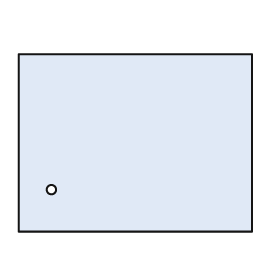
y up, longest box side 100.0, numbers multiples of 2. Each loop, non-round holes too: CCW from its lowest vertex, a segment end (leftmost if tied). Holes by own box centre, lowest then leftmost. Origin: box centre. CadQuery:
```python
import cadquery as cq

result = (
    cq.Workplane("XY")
    .moveTo(-50.0, -38.0)
    .lineTo(50.0, -38.0)
    .lineTo(50.0, 38.0)
    .lineTo(-50.0, 38.0)
    .close()
    .moveTo(-36.0, -20.0)
    .circle(2.0)
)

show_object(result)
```